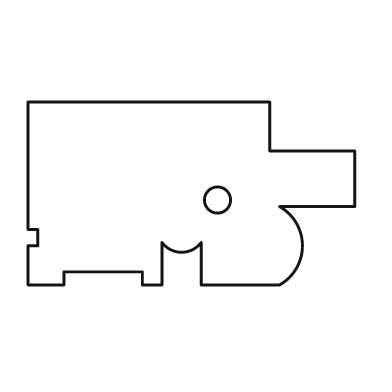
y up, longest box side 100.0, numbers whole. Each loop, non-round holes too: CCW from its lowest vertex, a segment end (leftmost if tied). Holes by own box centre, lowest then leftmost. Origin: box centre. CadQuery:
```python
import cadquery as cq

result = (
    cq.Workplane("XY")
    .moveTo(-50.0, -28.0)
    .lineTo(-39.0, -28.0)
    .lineTo(-39.0, -24.0)
    .lineTo(-15.0, -24.0)
    .lineTo(-15.0, -28.0)
    .lineTo(-9.0, -28.0)
    .lineTo(-9.0, -15.0)
    .threePointArc((-3.0, -18.0), (3.0, -15.0))
    .lineTo(3.0, -28.0)
    .lineTo(27.0, -28.0)
    .threePointArc((34.0, -16.0), (27.0, -4.0))
    .lineTo(50.0, -4.0)
    .lineTo(50.0, 13.0)
    .lineTo(24.0, 13.0)
    .lineTo(24.0, 28.0)
    .lineTo(-50.0, 28.0)
    .lineTo(-50.0, -11.0)
    .lineTo(-47.0, -11.0)
    .lineTo(-47.0, -16.0)
    .lineTo(-50.0, -16.0)
    .close()
    .moveTo(8.0, -2.0)
    .circle(4.0)
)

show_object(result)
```